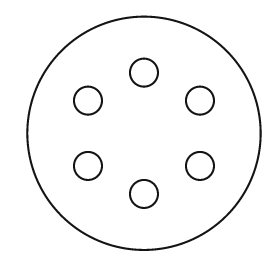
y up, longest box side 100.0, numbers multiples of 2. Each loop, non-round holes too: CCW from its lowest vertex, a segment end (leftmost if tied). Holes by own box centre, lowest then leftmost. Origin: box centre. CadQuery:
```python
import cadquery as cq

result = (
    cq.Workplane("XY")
    .moveTo(0.0, 0.0)
    .circle(50.0)
    .moveTo(0.0, -26.0)
    .circle(6.0)
    .moveTo(-24.0, -14.0)
    .circle(6.0)
    .moveTo(24.0, -14.0)
    .circle(6.0)
    .moveTo(-24.0, 14.0)
    .circle(6.0)
    .moveTo(24.0, 14.0)
    .circle(6.0)
    .moveTo(0.0, 26.0)
    .circle(6.0)
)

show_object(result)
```